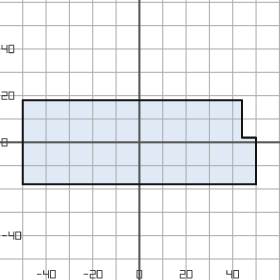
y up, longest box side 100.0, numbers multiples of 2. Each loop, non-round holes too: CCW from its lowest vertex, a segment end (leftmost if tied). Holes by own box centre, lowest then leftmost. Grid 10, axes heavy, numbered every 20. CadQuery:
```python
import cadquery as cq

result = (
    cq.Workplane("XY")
    .moveTo(-50.0, -18.0)
    .lineTo(50.0, -18.0)
    .lineTo(50.0, 2.0)
    .lineTo(44.0, 2.0)
    .lineTo(44.0, 18.0)
    .lineTo(-50.0, 18.0)
    .close()
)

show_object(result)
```